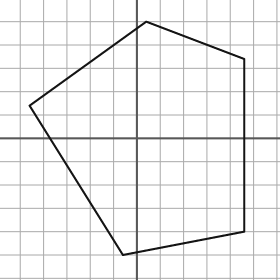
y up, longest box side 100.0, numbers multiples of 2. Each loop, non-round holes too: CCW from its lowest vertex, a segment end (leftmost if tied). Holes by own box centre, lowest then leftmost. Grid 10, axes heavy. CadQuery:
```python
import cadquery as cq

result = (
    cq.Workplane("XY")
    .moveTo(-6.0, -50.0)
    .lineTo(46.0, -40.0)
    .lineTo(46.0, 34.0)
    .lineTo(4.0, 50.0)
    .lineTo(-46.0, 14.0)
    .close()
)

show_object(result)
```